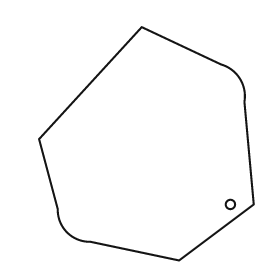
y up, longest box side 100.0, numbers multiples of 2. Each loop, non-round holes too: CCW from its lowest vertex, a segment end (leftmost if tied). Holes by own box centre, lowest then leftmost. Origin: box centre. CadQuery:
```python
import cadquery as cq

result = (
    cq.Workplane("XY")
    .moveTo(14.0, -50.0)
    .lineTo(46.0, -26.0)
    .lineTo(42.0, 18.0)
    .threePointArc((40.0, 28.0), (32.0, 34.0))
    .lineTo(-2.0, 50.0)
    .lineTo(-46.0, 2.0)
    .lineTo(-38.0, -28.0)
    .threePointArc((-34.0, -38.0), (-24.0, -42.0))
    .close()
    .moveTo(36.0, -26.0)
    .circle(2.0)
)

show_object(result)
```